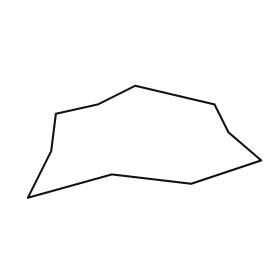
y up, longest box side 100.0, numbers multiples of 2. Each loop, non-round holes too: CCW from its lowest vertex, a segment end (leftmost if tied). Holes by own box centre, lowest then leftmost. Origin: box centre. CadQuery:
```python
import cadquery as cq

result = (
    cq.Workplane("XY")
    .moveTo(-50.0, -24.0)
    .lineTo(-14.0, -14.0)
    .lineTo(20.0, -18.0)
    .lineTo(50.0, -8.0)
    .lineTo(36.0, 4.0)
    .lineTo(30.0, 16.0)
    .lineTo(-4.0, 24.0)
    .lineTo(-20.0, 16.0)
    .lineTo(-38.0, 12.0)
    .lineTo(-40.0, -4.0)
    .close()
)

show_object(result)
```